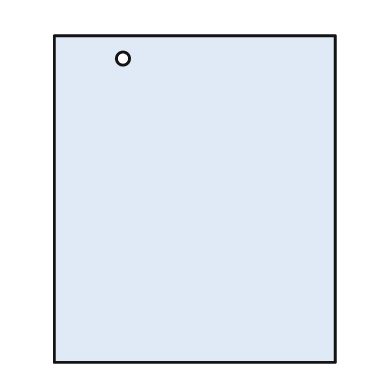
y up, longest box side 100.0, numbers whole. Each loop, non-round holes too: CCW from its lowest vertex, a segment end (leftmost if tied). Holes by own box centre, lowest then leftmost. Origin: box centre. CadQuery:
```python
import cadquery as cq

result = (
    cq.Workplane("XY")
    .moveTo(-43.0, -50.0)
    .lineTo(43.0, -50.0)
    .lineTo(43.0, 50.0)
    .lineTo(-43.0, 50.0)
    .close()
    .moveTo(-22.0, 43.0)
    .circle(2.0)
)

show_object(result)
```